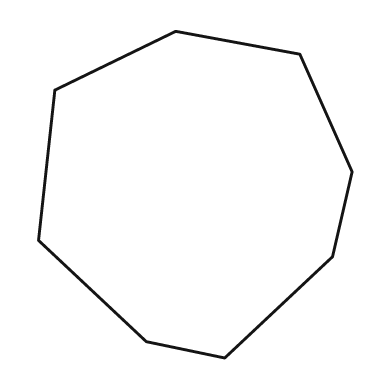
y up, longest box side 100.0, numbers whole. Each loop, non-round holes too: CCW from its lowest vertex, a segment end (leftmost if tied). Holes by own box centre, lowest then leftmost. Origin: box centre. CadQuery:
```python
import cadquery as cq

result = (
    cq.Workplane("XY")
    .moveTo(9.0, -50.0)
    .lineTo(42.0, -19.0)
    .lineTo(48.0, 7.0)
    .lineTo(32.0, 43.0)
    .lineTo(-6.0, 50.0)
    .lineTo(-43.0, 32.0)
    .lineTo(-48.0, -14.0)
    .lineTo(-15.0, -45.0)
    .close()
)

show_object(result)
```